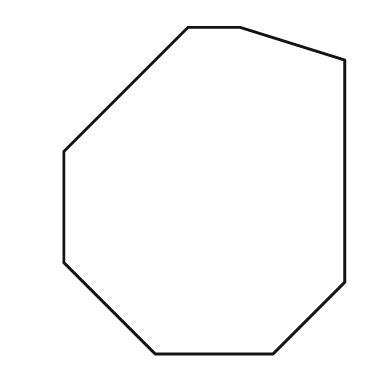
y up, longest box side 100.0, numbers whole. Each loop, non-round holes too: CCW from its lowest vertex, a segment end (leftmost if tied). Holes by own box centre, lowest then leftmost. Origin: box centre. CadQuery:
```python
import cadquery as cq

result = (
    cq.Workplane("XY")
    .moveTo(-15.0, -50.0)
    .lineTo(21.0, -50.0)
    .lineTo(43.0, -28.0)
    .lineTo(43.0, 40.0)
    .lineTo(11.0, 50.0)
    .lineTo(-5.0, 50.0)
    .lineTo(-43.0, 12.0)
    .lineTo(-43.0, -22.0)
    .close()
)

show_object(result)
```